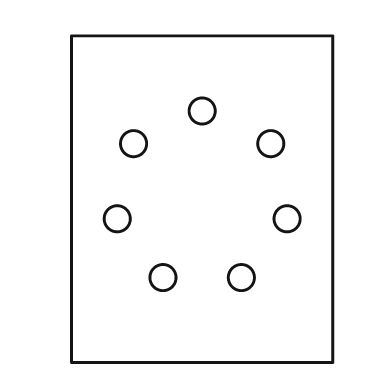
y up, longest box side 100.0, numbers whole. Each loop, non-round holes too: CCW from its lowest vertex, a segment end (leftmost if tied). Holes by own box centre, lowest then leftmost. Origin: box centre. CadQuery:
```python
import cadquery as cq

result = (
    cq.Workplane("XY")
    .moveTo(-40.0, -50.0)
    .lineTo(40.0, -50.0)
    .lineTo(40.0, 50.0)
    .lineTo(-40.0, 50.0)
    .close()
    .moveTo(-12.0, -24.0)
    .circle(4.0)
    .moveTo(12.0, -24.0)
    .circle(4.0)
    .moveTo(-26.0, -6.0)
    .circle(4.0)
    .moveTo(26.0, -6.0)
    .circle(4.0)
    .moveTo(-21.0, 17.0)
    .circle(4.0)
    .moveTo(21.0, 17.0)
    .circle(4.0)
    .moveTo(0.0, 27.0)
    .circle(4.0)
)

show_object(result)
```